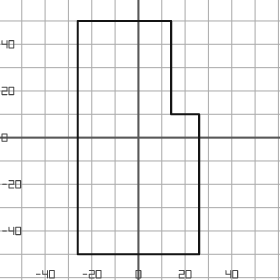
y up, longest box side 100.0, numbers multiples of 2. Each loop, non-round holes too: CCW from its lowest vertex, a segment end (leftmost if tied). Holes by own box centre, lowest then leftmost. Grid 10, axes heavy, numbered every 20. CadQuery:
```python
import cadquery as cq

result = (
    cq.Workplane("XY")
    .moveTo(-26.0, -50.0)
    .lineTo(26.0, -50.0)
    .lineTo(26.0, 10.0)
    .lineTo(14.0, 10.0)
    .lineTo(14.0, 50.0)
    .lineTo(-26.0, 50.0)
    .close()
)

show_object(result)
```